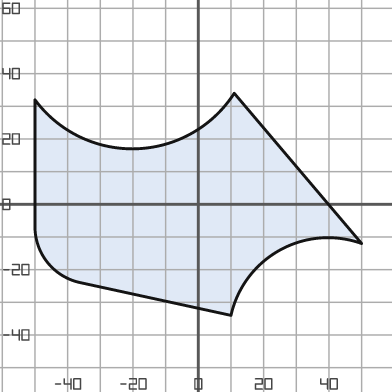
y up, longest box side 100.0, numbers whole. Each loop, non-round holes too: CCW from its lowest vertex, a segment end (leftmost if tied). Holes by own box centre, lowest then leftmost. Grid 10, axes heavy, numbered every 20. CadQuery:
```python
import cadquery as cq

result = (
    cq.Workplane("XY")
    .moveTo(10.0, -34.0)
    .threePointArc((25.0, -14.0), (50.0, -12.0))
    .lineTo(11.0, 34.0)
    .threePointArc((-19.0, 17.0), (-50.0, 32.0))
    .lineTo(-50.0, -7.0)
    .threePointArc((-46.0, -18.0), (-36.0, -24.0))
    .close()
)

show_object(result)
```